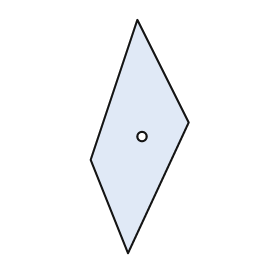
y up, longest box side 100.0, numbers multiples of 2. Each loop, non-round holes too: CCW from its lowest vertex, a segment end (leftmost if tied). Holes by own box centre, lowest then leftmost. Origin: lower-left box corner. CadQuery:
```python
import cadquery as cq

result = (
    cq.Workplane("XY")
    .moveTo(16.0, 0.0)
    .lineTo(42.0, 56.0)
    .lineTo(20.0, 100.0)
    .lineTo(0.0, 40.0)
    .close()
    .moveTo(22.0, 50.0)
    .circle(2.0)
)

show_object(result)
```